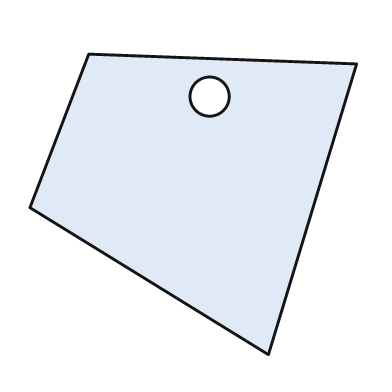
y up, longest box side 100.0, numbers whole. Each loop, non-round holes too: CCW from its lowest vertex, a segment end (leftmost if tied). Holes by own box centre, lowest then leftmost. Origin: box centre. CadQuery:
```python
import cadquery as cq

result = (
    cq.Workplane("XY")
    .moveTo(23.0, -46.0)
    .lineTo(50.0, 43.0)
    .lineTo(-32.0, 46.0)
    .lineTo(-50.0, -1.0)
    .close()
    .moveTo(5.0, 33.0)
    .circle(6.0)
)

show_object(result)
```